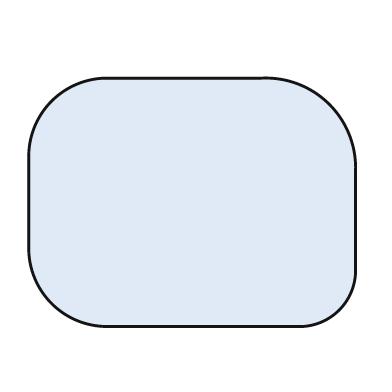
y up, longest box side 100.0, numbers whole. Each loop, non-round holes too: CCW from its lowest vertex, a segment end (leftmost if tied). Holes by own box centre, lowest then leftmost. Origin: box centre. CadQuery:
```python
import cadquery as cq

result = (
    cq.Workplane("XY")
    .moveTo(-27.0, -38.0)
    .lineTo(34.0, -38.0)
    .threePointArc((45.0, -33.0), (50.0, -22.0))
    .lineTo(50.0, 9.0)
    .threePointArc((42.0, 30.0), (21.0, 38.0))
    .lineTo(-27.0, 38.0)
    .threePointArc((-43.0, 31.0), (-50.0, 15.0))
    .lineTo(-50.0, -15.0)
    .threePointArc((-43.0, -31.0), (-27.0, -38.0))
    .close()
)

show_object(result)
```